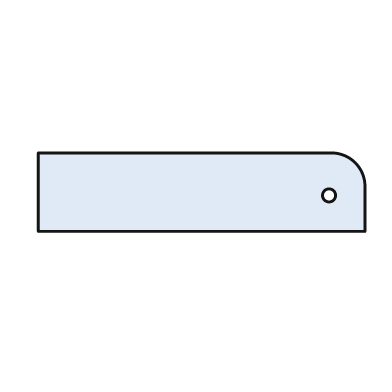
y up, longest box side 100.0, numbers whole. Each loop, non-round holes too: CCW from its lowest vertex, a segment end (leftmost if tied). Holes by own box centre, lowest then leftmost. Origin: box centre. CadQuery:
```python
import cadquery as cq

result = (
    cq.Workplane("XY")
    .moveTo(-50.0, -12.0)
    .lineTo(50.0, -12.0)
    .lineTo(50.0, 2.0)
    .threePointArc((47.0, 9.0), (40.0, 12.0))
    .lineTo(-50.0, 12.0)
    .close()
    .moveTo(39.0, -1.0)
    .circle(2.0)
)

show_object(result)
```